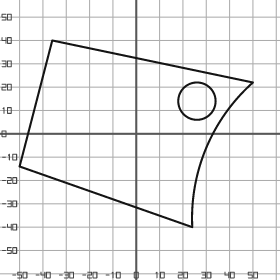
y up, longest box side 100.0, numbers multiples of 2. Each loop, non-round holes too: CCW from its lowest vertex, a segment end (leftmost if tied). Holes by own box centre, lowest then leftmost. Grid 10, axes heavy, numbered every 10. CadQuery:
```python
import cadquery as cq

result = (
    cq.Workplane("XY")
    .moveTo(24.0, -40.0)
    .threePointArc((30.0, -6.0), (50.0, 22.0))
    .lineTo(-36.0, 40.0)
    .lineTo(-50.0, -14.0)
    .close()
    .moveTo(26.0, 14.0)
    .circle(8.0)
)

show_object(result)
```